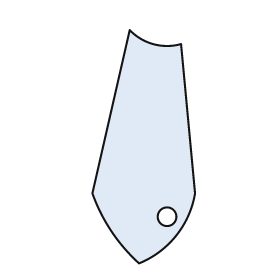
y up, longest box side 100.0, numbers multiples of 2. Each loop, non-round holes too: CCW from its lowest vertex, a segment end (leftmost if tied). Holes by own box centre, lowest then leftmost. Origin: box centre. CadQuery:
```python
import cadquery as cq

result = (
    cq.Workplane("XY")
    .moveTo(-2.0, -50.0)
    .threePointArc((14.0, -38.0), (22.0, -20.0))
    .lineTo(16.0, 44.0)
    .threePointArc((4.0, 44.0), (-6.0, 50.0))
    .lineTo(-22.0, -20.0)
    .threePointArc((-14.0, -36.0), (-2.0, -50.0))
    .close()
    .moveTo(10.0, -30.0)
    .circle(4.0)
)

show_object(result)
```